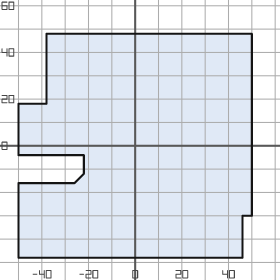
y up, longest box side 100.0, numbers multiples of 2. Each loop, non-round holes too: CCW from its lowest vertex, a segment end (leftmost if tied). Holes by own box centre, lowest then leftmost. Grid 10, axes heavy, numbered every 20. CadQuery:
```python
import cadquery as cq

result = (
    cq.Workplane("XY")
    .moveTo(-50.0, -48.0)
    .lineTo(46.0, -48.0)
    .lineTo(46.0, -30.0)
    .lineTo(50.0, -30.0)
    .lineTo(50.0, 48.0)
    .lineTo(-38.0, 48.0)
    .lineTo(-38.0, 18.0)
    .lineTo(-50.0, 18.0)
    .lineTo(-50.0, -4.0)
    .lineTo(-22.0, -4.0)
    .lineTo(-22.0, -12.0)
    .lineTo(-26.0, -16.0)
    .lineTo(-50.0, -16.0)
    .close()
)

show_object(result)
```